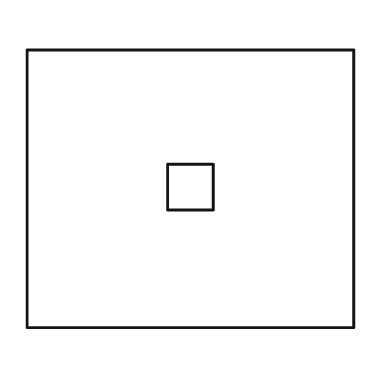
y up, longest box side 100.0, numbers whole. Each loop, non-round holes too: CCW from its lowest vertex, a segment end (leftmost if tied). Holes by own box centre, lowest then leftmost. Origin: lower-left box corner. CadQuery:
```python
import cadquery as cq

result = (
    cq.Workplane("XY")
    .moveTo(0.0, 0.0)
    .lineTo(100.0, 0.0)
    .lineTo(100.0, 85.0)
    .lineTo(0.0, 85.0)
    .close()
    .moveTo(43.0, 36.0)
    .lineTo(57.0, 36.0)
    .lineTo(57.0, 50.0)
    .lineTo(43.0, 50.0)
    .close()
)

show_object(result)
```